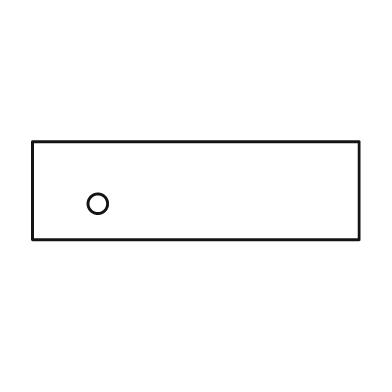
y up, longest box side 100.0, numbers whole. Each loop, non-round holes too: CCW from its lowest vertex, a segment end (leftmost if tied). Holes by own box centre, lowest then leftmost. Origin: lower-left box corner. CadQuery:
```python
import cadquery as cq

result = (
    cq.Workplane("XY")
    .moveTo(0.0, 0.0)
    .lineTo(100.0, 0.0)
    .lineTo(100.0, 30.0)
    .lineTo(0.0, 30.0)
    .close()
    .moveTo(20.0, 11.0)
    .circle(3.0)
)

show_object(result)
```